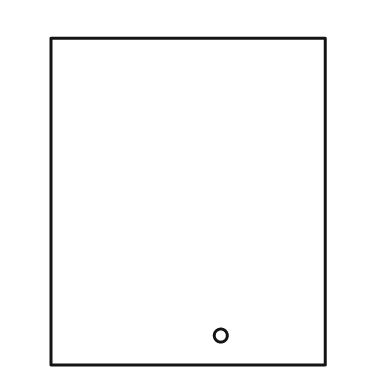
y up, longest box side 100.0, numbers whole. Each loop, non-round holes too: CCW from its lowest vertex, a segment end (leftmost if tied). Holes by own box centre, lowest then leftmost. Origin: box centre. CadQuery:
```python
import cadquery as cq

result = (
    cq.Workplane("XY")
    .moveTo(-42.0, -50.0)
    .lineTo(42.0, -50.0)
    .lineTo(42.0, 50.0)
    .lineTo(-42.0, 50.0)
    .close()
    .moveTo(10.0, -41.0)
    .circle(2.0)
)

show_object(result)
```